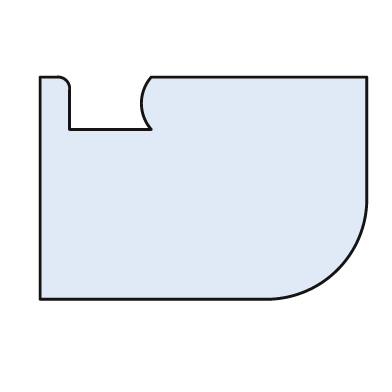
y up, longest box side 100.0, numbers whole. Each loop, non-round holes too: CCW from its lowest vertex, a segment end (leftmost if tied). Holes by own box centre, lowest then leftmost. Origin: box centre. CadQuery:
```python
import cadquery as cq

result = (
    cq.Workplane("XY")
    .moveTo(-50.0, -34.0)
    .lineTo(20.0, -34.0)
    .threePointArc((41.0, -25.0), (50.0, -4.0))
    .lineTo(50.0, 34.0)
    .lineTo(-16.0, 34.0)
    .threePointArc((-19.0, 26.0), (-16.0, 18.0))
    .lineTo(-41.0, 18.0)
    .lineTo(-41.0, 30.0)
    .threePointArc((-42.0, 33.0), (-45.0, 34.0))
    .lineTo(-50.0, 34.0)
    .close()
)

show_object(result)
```